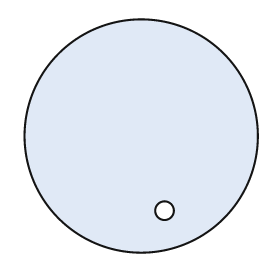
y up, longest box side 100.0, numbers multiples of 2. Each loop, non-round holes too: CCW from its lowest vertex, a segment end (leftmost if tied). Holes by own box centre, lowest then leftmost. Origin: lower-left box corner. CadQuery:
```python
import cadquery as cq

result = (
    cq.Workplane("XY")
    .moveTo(50.0, 50.0)
    .circle(50.0)
    .moveTo(60.0, 18.0)
    .circle(4.0)
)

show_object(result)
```